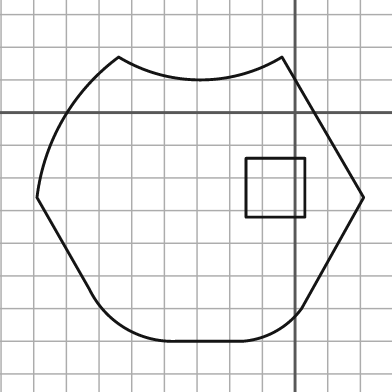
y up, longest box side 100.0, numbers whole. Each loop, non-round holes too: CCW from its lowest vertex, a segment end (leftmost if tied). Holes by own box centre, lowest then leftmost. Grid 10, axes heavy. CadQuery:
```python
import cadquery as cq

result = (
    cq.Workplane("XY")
    .moveTo(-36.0, -70.0)
    .lineTo(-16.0, -70.0)
    .threePointArc((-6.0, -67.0), (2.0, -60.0))
    .lineTo(21.0, -26.0)
    .lineTo(-4.0, 17.0)
    .threePointArc((-29.0, 10.0), (-54.0, 17.0))
    .threePointArc((-71.0, -2.0), (-79.0, -26.0))
    .lineTo(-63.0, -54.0)
    .threePointArc((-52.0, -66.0), (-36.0, -70.0))
    .close()
    .moveTo(-15.0, -32.0)
    .lineTo(3.0, -32.0)
    .lineTo(3.0, -14.0)
    .lineTo(-15.0, -14.0)
    .close()
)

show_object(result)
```